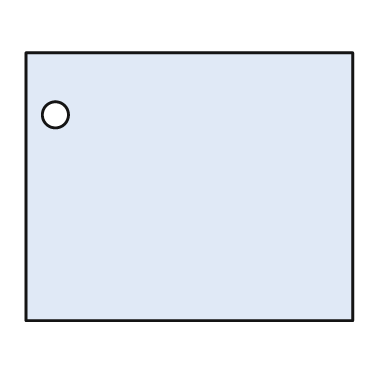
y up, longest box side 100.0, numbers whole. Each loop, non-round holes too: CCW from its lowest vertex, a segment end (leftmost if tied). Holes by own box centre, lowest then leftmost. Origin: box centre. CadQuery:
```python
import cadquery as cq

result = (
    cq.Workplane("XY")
    .moveTo(-50.0, -41.0)
    .lineTo(50.0, -41.0)
    .lineTo(50.0, 41.0)
    .lineTo(-50.0, 41.0)
    .close()
    .moveTo(-41.0, 22.0)
    .circle(4.0)
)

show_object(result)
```